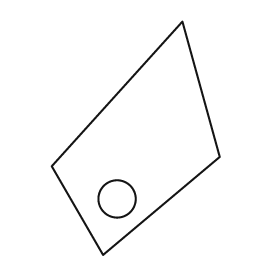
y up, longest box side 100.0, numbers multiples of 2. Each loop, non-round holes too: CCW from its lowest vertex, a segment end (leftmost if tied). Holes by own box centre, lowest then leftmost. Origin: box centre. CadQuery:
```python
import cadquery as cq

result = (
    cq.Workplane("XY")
    .moveTo(-14.0, -50.0)
    .lineTo(36.0, -8.0)
    .lineTo(20.0, 50.0)
    .lineTo(-36.0, -12.0)
    .close()
    .moveTo(-8.0, -26.0)
    .circle(8.0)
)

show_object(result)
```